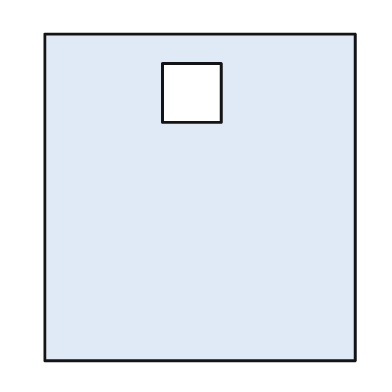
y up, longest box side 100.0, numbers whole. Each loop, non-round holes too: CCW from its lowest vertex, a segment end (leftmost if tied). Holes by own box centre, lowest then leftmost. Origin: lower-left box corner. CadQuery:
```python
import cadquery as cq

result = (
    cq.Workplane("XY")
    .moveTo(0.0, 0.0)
    .lineTo(95.0, 0.0)
    .lineTo(95.0, 100.0)
    .lineTo(0.0, 100.0)
    .close()
    .moveTo(36.0, 73.0)
    .lineTo(54.0, 73.0)
    .lineTo(54.0, 91.0)
    .lineTo(36.0, 91.0)
    .close()
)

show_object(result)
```